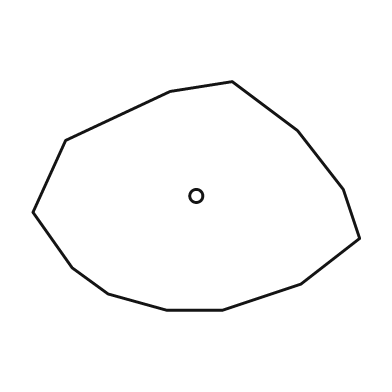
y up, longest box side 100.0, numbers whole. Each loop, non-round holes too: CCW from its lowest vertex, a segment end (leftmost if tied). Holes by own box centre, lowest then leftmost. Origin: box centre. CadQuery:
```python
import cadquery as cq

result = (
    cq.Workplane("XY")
    .moveTo(-9.0, -35.0)
    .lineTo(8.0, -35.0)
    .lineTo(32.0, -27.0)
    .lineTo(50.0, -13.0)
    .lineTo(45.0, 2.0)
    .lineTo(31.0, 20.0)
    .lineTo(11.0, 35.0)
    .lineTo(-8.0, 32.0)
    .lineTo(-40.0, 17.0)
    .lineTo(-50.0, -5.0)
    .lineTo(-38.0, -22.0)
    .lineTo(-27.0, -30.0)
    .close()
    .moveTo(0.0, 0.0)
    .circle(2.0)
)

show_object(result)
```